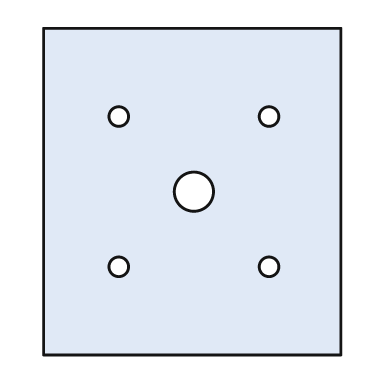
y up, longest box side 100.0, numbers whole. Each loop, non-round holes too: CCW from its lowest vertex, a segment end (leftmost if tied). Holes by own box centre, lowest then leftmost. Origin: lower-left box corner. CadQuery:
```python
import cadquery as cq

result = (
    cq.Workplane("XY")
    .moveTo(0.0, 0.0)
    .lineTo(91.0, 0.0)
    .lineTo(91.0, 100.0)
    .lineTo(0.0, 100.0)
    .close()
    .moveTo(23.0, 27.0)
    .circle(3.0)
    .moveTo(69.0, 27.0)
    .circle(3.0)
    .moveTo(46.0, 50.0)
    .circle(6.0)
    .moveTo(23.0, 73.0)
    .circle(3.0)
    .moveTo(69.0, 73.0)
    .circle(3.0)
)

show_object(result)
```